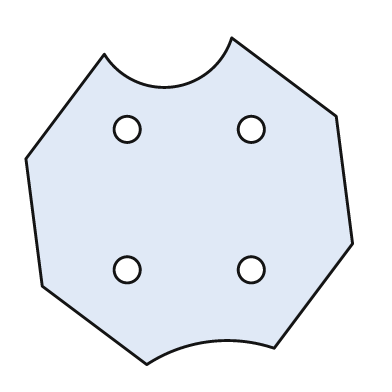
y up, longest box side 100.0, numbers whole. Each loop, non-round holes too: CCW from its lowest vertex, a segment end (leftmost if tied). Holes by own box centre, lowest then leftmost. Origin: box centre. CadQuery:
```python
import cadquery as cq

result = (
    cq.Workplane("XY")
    .moveTo(-13.0, -50.0)
    .threePointArc((6.0, -43.0), (26.0, -45.0))
    .lineTo(50.0, -13.0)
    .lineTo(45.0, 26.0)
    .lineTo(13.0, 50.0)
    .threePointArc((-5.0, 35.0), (-26.0, 45.0))
    .lineTo(-50.0, 13.0)
    .lineTo(-45.0, -26.0)
    .close()
    .moveTo(-19.0, -21.0)
    .circle(4.0)
    .moveTo(19.0, -21.0)
    .circle(4.0)
    .moveTo(-19.0, 22.0)
    .circle(4.0)
    .moveTo(19.0, 22.0)
    .circle(4.0)
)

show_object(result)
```